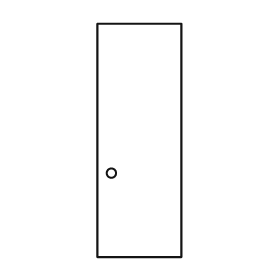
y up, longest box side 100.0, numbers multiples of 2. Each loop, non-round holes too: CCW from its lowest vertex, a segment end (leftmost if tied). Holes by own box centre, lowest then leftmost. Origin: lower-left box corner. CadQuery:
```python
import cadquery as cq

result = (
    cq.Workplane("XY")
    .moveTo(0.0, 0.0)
    .lineTo(36.0, 0.0)
    .lineTo(36.0, 100.0)
    .lineTo(0.0, 100.0)
    .close()
    .moveTo(6.0, 36.0)
    .circle(2.0)
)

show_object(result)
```